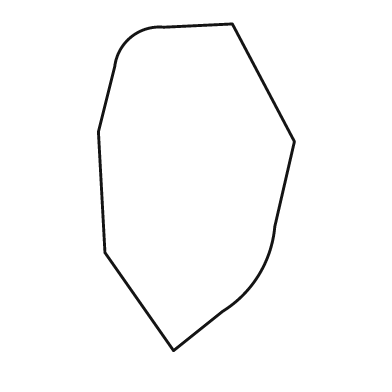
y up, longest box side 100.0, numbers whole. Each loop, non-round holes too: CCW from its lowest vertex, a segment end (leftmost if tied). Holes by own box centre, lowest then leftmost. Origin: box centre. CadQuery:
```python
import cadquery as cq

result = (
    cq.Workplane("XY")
    .moveTo(-7.0, -50.0)
    .lineTo(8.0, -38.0)
    .threePointArc((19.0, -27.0), (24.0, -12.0))
    .lineTo(30.0, 14.0)
    .lineTo(11.0, 50.0)
    .lineTo(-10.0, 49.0)
    .threePointArc((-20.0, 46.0), (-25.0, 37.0))
    .lineTo(-30.0, 17.0)
    .lineTo(-28.0, -20.0)
    .close()
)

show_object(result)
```